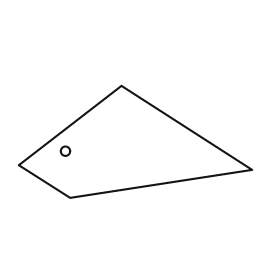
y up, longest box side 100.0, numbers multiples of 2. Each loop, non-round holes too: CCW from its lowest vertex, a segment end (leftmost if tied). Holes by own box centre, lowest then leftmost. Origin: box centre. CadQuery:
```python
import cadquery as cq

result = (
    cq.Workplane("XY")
    .moveTo(-28.0, -24.0)
    .lineTo(50.0, -12.0)
    .lineTo(-6.0, 24.0)
    .lineTo(-50.0, -10.0)
    .close()
    .moveTo(-30.0, -4.0)
    .circle(2.0)
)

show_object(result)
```